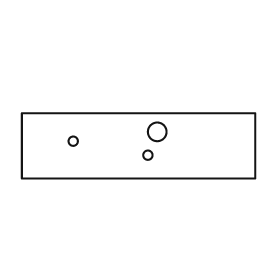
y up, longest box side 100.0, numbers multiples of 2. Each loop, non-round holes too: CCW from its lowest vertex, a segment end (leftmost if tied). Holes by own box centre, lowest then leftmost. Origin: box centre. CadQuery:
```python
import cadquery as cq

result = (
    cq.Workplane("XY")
    .moveTo(-50.0, -14.0)
    .lineTo(50.0, -14.0)
    .lineTo(50.0, 14.0)
    .lineTo(-50.0, 14.0)
    .close()
    .moveTo(4.0, -4.0)
    .circle(2.0)
    .moveTo(-28.0, 2.0)
    .circle(2.0)
    .moveTo(8.0, 6.0)
    .circle(4.0)
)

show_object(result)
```